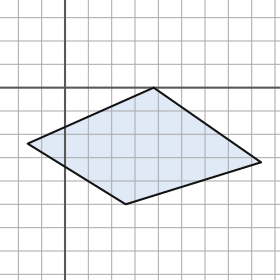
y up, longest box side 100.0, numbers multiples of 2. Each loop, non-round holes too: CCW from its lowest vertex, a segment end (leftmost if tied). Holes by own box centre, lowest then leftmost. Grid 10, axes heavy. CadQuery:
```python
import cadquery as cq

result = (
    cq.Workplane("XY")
    .moveTo(26.0, -50.0)
    .lineTo(84.0, -32.0)
    .lineTo(38.0, 0.0)
    .lineTo(-16.0, -24.0)
    .close()
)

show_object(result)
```